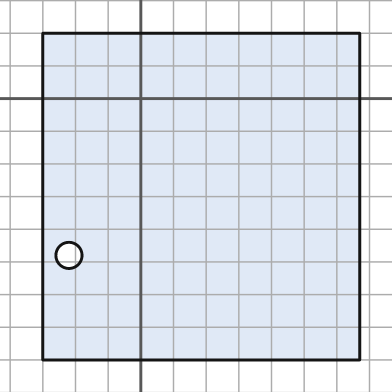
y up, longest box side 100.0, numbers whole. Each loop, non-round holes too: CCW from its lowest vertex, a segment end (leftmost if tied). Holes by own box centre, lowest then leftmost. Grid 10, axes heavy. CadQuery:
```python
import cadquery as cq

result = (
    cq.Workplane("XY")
    .moveTo(-30.0, -80.0)
    .lineTo(67.0, -80.0)
    .lineTo(67.0, 20.0)
    .lineTo(-30.0, 20.0)
    .close()
    .moveTo(-22.0, -48.0)
    .circle(4.0)
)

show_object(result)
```